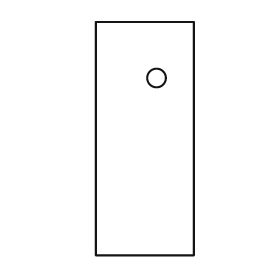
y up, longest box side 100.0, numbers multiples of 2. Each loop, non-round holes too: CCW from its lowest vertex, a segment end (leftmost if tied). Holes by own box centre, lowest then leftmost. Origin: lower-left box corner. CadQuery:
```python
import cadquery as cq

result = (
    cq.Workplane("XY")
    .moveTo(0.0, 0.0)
    .lineTo(42.0, 0.0)
    .lineTo(42.0, 100.0)
    .lineTo(0.0, 100.0)
    .close()
    .moveTo(26.0, 76.0)
    .circle(4.0)
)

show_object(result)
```